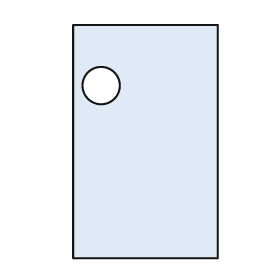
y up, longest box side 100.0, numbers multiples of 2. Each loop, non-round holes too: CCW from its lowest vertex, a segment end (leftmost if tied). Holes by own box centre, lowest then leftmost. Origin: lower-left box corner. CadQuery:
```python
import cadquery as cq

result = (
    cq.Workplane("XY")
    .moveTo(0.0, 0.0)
    .lineTo(62.0, 0.0)
    .lineTo(62.0, 100.0)
    .lineTo(0.0, 100.0)
    .close()
    .moveTo(12.0, 74.0)
    .circle(8.0)
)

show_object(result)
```